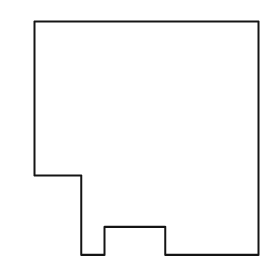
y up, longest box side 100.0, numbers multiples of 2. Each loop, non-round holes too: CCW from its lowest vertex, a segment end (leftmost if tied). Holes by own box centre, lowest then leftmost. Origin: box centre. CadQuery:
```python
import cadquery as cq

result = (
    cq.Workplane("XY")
    .moveTo(-28.0, -50.0)
    .lineTo(-18.0, -50.0)
    .lineTo(-18.0, -38.0)
    .lineTo(8.0, -38.0)
    .lineTo(8.0, -50.0)
    .lineTo(48.0, -50.0)
    .lineTo(48.0, 50.0)
    .lineTo(-48.0, 50.0)
    .lineTo(-48.0, -16.0)
    .lineTo(-28.0, -16.0)
    .close()
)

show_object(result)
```